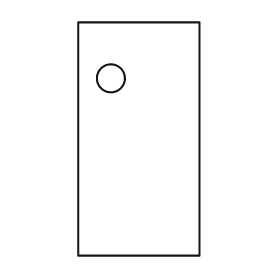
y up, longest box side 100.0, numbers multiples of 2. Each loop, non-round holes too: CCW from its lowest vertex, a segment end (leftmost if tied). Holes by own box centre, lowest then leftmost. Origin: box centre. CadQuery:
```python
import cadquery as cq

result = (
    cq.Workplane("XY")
    .moveTo(-26.0, -50.0)
    .lineTo(26.0, -50.0)
    .lineTo(26.0, 50.0)
    .lineTo(-26.0, 50.0)
    .close()
    .moveTo(-12.0, 26.0)
    .circle(6.0)
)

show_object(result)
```